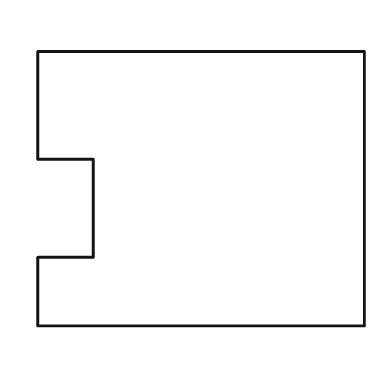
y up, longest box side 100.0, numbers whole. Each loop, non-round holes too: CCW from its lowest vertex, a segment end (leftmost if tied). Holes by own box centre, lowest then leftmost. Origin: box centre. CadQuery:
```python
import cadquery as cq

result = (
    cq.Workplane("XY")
    .moveTo(-50.0, -42.0)
    .lineTo(50.0, -42.0)
    .lineTo(50.0, 42.0)
    .lineTo(-50.0, 42.0)
    .lineTo(-50.0, 9.0)
    .lineTo(-33.0, 9.0)
    .lineTo(-33.0, -21.0)
    .lineTo(-50.0, -21.0)
    .close()
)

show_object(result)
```